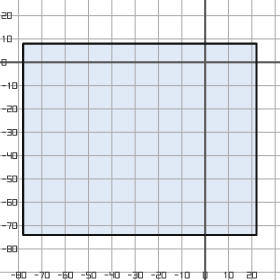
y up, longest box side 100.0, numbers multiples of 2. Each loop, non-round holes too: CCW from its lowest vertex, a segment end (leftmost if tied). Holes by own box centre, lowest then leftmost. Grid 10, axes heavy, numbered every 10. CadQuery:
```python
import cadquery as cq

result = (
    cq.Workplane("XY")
    .moveTo(-78.0, -74.0)
    .lineTo(22.0, -74.0)
    .lineTo(22.0, 8.0)
    .lineTo(-78.0, 8.0)
    .close()
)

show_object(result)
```